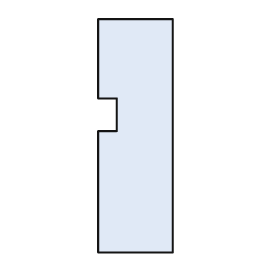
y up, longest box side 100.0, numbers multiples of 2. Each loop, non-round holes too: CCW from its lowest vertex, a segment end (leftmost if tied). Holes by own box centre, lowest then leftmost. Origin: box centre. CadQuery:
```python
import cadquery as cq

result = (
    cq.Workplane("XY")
    .moveTo(-16.0, -50.0)
    .lineTo(16.0, -50.0)
    .lineTo(16.0, 50.0)
    .lineTo(-16.0, 50.0)
    .lineTo(-16.0, 16.0)
    .lineTo(-8.0, 16.0)
    .lineTo(-8.0, 2.0)
    .lineTo(-16.0, 2.0)
    .close()
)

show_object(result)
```